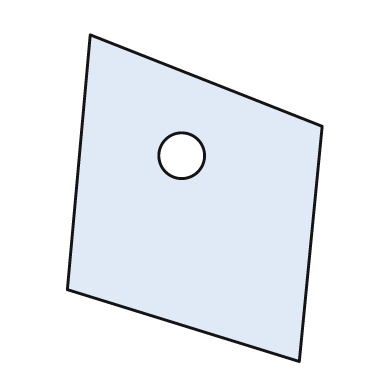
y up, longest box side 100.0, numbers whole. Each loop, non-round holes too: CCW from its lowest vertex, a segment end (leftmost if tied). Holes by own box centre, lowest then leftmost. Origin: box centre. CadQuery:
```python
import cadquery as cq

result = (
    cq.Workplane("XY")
    .moveTo(32.0, -50.0)
    .lineTo(39.0, 22.0)
    .lineTo(-32.0, 50.0)
    .lineTo(-39.0, -28.0)
    .close()
    .moveTo(-4.0, 13.0)
    .circle(7.0)
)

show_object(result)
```